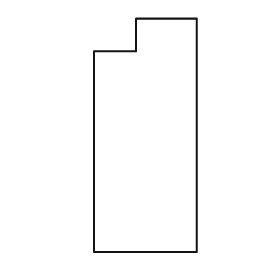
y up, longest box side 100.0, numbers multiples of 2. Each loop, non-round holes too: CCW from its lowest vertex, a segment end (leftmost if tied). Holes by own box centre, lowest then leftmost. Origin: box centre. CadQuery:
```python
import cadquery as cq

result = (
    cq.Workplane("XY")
    .moveTo(-22.0, -50.0)
    .lineTo(22.0, -50.0)
    .lineTo(22.0, 50.0)
    .lineTo(-4.0, 50.0)
    .lineTo(-4.0, 36.0)
    .lineTo(-22.0, 36.0)
    .close()
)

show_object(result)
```